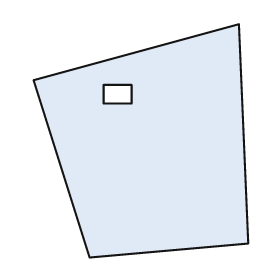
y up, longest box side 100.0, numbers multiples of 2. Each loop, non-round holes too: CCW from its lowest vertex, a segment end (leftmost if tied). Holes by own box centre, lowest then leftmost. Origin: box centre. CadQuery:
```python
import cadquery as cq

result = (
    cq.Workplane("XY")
    .moveTo(-22.0, -50.0)
    .lineTo(46.0, -44.0)
    .lineTo(42.0, 50.0)
    .lineTo(-46.0, 26.0)
    .close()
    .moveTo(-16.0, 16.0)
    .lineTo(-4.0, 16.0)
    .lineTo(-4.0, 24.0)
    .lineTo(-16.0, 24.0)
    .close()
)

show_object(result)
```